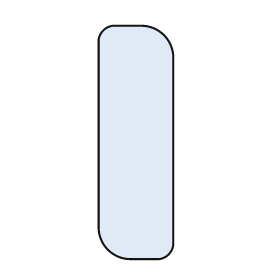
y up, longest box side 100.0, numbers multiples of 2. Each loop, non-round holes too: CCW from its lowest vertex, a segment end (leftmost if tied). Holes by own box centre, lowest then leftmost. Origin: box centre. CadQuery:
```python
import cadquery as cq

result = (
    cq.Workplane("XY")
    .moveTo(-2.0, -50.0)
    .lineTo(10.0, -50.0)
    .threePointArc((14.0, -48.0), (16.0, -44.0))
    .lineTo(16.0, 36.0)
    .threePointArc((12.0, 46.0), (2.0, 50.0))
    .lineTo(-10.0, 50.0)
    .threePointArc((-14.0, 48.0), (-16.0, 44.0))
    .lineTo(-16.0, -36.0)
    .threePointArc((-12.0, -46.0), (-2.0, -50.0))
    .close()
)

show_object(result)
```